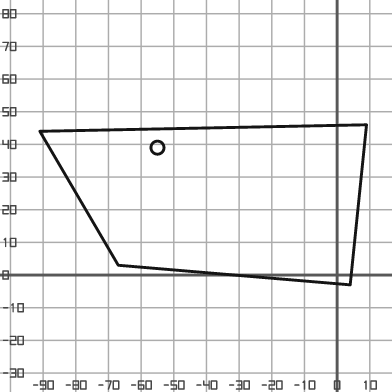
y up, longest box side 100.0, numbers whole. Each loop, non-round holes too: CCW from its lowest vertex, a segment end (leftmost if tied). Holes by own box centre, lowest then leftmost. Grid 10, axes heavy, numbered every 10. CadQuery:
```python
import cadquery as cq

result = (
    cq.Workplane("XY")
    .moveTo(4.0, -3.0)
    .lineTo(9.0, 46.0)
    .lineTo(-91.0, 44.0)
    .lineTo(-67.0, 3.0)
    .close()
    .moveTo(-55.0, 39.0)
    .circle(2.0)
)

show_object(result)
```